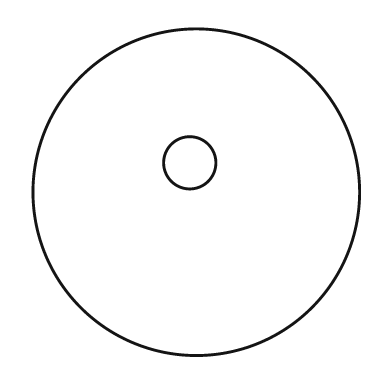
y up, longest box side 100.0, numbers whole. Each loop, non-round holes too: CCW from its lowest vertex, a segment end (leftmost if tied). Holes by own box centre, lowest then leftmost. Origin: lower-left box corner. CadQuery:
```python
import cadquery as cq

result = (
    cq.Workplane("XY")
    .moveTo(50.0, 50.0)
    .circle(50.0)
    .moveTo(48.0, 59.0)
    .circle(8.0)
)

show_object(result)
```